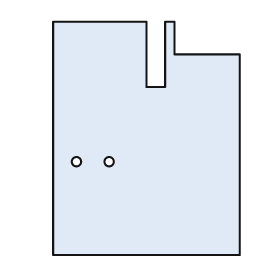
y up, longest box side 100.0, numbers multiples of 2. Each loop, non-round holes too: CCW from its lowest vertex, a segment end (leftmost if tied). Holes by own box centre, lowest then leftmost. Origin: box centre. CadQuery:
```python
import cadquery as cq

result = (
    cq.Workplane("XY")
    .moveTo(-40.0, -50.0)
    .lineTo(40.0, -50.0)
    .lineTo(40.0, 36.0)
    .lineTo(12.0, 36.0)
    .lineTo(12.0, 50.0)
    .lineTo(8.0, 50.0)
    .lineTo(8.0, 22.0)
    .lineTo(0.0, 22.0)
    .lineTo(0.0, 50.0)
    .lineTo(-40.0, 50.0)
    .close()
    .moveTo(-30.0, -10.0)
    .circle(2.0)
    .moveTo(-16.0, -10.0)
    .circle(2.0)
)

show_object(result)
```